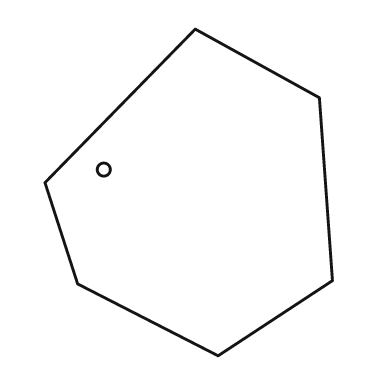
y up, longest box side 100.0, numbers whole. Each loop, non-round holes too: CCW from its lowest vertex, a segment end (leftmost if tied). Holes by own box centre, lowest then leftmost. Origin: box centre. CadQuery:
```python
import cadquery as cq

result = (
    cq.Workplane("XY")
    .moveTo(9.0, -50.0)
    .lineTo(44.0, -27.0)
    .lineTo(40.0, 29.0)
    .lineTo(2.0, 50.0)
    .lineTo(-44.0, 3.0)
    .lineTo(-34.0, -28.0)
    .close()
    .moveTo(-26.0, 7.0)
    .circle(2.0)
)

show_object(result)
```